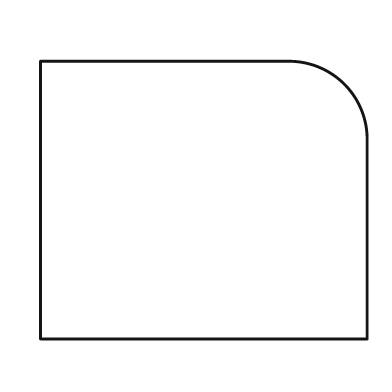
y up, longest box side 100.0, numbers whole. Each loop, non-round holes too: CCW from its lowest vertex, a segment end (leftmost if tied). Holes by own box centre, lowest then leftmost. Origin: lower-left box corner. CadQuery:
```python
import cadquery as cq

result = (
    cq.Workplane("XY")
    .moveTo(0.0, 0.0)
    .lineTo(100.0, 0.0)
    .lineTo(100.0, 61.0)
    .threePointArc((93.0, 78.0), (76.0, 85.0))
    .lineTo(0.0, 85.0)
    .close()
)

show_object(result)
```